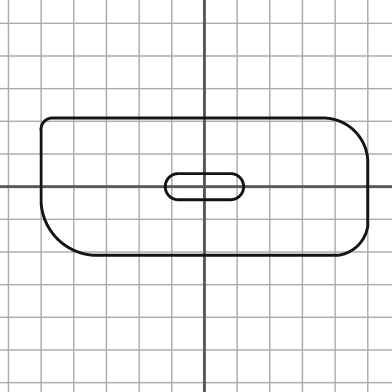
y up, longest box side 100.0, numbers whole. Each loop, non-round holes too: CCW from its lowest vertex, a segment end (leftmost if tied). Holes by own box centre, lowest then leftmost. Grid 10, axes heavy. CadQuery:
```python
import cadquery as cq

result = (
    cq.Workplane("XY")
    .moveTo(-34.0, -21.0)
    .lineTo(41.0, -21.0)
    .threePointArc((47.0, -18.0), (50.0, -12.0))
    .lineTo(50.0, 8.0)
    .threePointArc((46.0, 17.0), (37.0, 21.0))
    .lineTo(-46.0, 21.0)
    .threePointArc((-49.0, 20.0), (-50.0, 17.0))
    .lineTo(-50.0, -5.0)
    .threePointArc((-45.0, -16.0), (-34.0, -21.0))
    .close()
    .moveTo(-8.0, -4.0)
    .lineTo(8.0, -4.0)
    .threePointArc((12.0, 0.0), (8.0, 4.0))
    .lineTo(-8.0, 4.0)
    .threePointArc((-12.0, 0.0), (-8.0, -4.0))
    .close()
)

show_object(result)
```